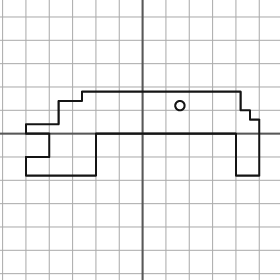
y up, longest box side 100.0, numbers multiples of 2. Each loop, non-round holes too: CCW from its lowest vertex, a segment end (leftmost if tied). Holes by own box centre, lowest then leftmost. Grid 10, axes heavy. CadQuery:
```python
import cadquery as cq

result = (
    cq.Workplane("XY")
    .moveTo(-50.0, -18.0)
    .lineTo(-20.0, -18.0)
    .lineTo(-20.0, 0.0)
    .lineTo(40.0, 0.0)
    .lineTo(40.0, -18.0)
    .lineTo(50.0, -18.0)
    .lineTo(50.0, 6.0)
    .lineTo(46.0, 6.0)
    .lineTo(46.0, 10.0)
    .lineTo(42.0, 10.0)
    .lineTo(42.0, 18.0)
    .lineTo(-26.0, 18.0)
    .lineTo(-26.0, 14.0)
    .lineTo(-36.0, 14.0)
    .lineTo(-36.0, 4.0)
    .lineTo(-50.0, 4.0)
    .lineTo(-50.0, 0.0)
    .lineTo(-40.0, 0.0)
    .lineTo(-40.0, -10.0)
    .lineTo(-50.0, -10.0)
    .close()
    .moveTo(16.0, 12.0)
    .circle(2.0)
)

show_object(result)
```